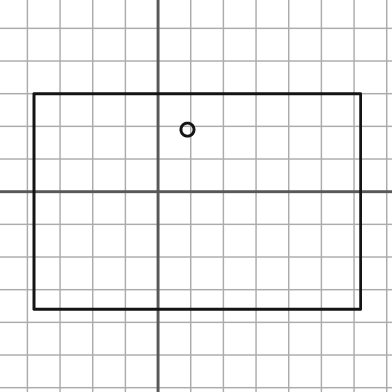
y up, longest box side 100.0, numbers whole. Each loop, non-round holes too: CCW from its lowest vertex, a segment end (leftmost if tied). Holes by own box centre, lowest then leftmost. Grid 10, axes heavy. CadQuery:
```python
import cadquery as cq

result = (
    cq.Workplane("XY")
    .moveTo(-38.0, -36.0)
    .lineTo(62.0, -36.0)
    .lineTo(62.0, 30.0)
    .lineTo(-38.0, 30.0)
    .close()
    .moveTo(9.0, 19.0)
    .circle(2.0)
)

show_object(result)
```